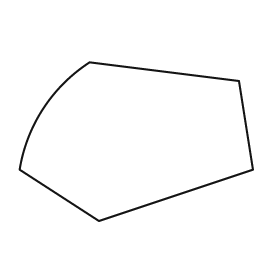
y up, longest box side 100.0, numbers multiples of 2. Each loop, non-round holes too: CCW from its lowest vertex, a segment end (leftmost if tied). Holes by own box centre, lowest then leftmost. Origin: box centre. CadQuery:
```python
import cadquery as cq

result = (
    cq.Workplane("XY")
    .moveTo(-16.0, -34.0)
    .lineTo(50.0, -12.0)
    .lineTo(44.0, 26.0)
    .lineTo(-20.0, 34.0)
    .threePointArc((-40.0, 14.0), (-50.0, -12.0))
    .close()
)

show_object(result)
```